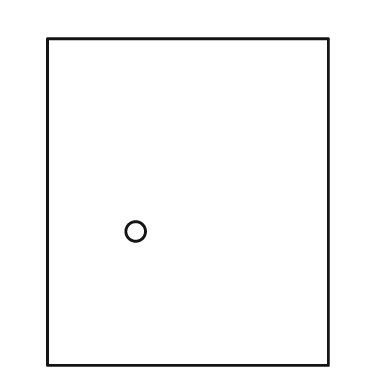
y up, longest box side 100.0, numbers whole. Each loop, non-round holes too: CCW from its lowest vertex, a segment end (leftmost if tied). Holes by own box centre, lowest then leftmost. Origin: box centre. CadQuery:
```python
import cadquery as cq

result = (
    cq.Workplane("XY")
    .moveTo(-43.0, -50.0)
    .lineTo(43.0, -50.0)
    .lineTo(43.0, 50.0)
    .lineTo(-43.0, 50.0)
    .close()
    .moveTo(-16.0, -9.0)
    .circle(3.0)
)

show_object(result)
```